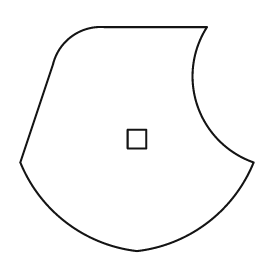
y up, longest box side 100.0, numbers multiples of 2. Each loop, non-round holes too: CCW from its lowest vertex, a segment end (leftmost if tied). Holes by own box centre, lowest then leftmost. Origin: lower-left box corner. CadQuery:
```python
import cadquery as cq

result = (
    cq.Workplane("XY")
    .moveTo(50.0, 0.0)
    .threePointArc((80.0, 12.0), (100.0, 38.0))
    .threePointArc((76.0, 62.0), (80.0, 96.0))
    .lineTo(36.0, 96.0)
    .threePointArc((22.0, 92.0), (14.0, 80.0))
    .lineTo(0.0, 38.0)
    .threePointArc((20.0, 12.0), (50.0, 0.0))
    .close()
    .moveTo(46.0, 44.0)
    .lineTo(54.0, 44.0)
    .lineTo(54.0, 52.0)
    .lineTo(46.0, 52.0)
    .close()
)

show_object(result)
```